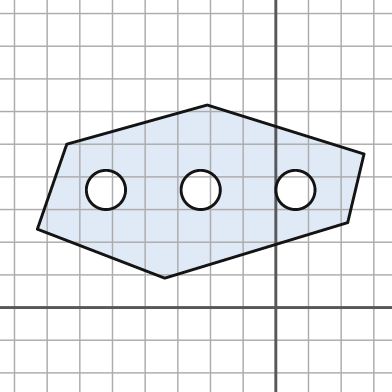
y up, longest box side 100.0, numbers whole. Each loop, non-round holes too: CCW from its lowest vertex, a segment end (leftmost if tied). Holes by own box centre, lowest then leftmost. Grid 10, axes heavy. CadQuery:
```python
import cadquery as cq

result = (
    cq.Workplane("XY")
    .moveTo(-34.0, 9.0)
    .lineTo(22.0, 26.0)
    .lineTo(27.0, 47.0)
    .lineTo(-21.0, 62.0)
    .lineTo(-64.0, 50.0)
    .lineTo(-73.0, 24.0)
    .close()
    .moveTo(-52.0, 36.0)
    .circle(6.0)
    .moveTo(-23.0, 36.0)
    .circle(6.0)
    .moveTo(6.0, 36.0)
    .circle(6.0)
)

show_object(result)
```